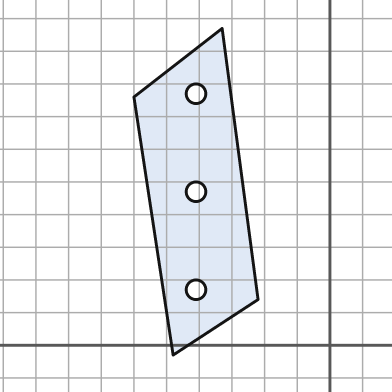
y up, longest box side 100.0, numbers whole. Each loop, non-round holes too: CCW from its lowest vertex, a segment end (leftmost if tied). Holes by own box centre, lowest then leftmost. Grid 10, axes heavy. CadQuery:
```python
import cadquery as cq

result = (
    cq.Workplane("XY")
    .moveTo(-48.0, -3.0)
    .lineTo(-22.0, 14.0)
    .lineTo(-33.0, 97.0)
    .lineTo(-60.0, 76.0)
    .close()
    .moveTo(-41.0, 17.0)
    .circle(3.0)
    .moveTo(-41.0, 47.0)
    .circle(3.0)
    .moveTo(-41.0, 77.0)
    .circle(3.0)
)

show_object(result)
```